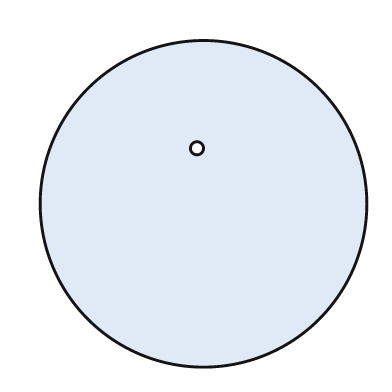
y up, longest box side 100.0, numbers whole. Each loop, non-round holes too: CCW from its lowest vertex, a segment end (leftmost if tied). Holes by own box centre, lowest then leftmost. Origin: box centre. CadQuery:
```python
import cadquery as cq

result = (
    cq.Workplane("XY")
    .moveTo(0.0, 0.0)
    .circle(50.0)
    .moveTo(-2.0, 17.0)
    .circle(2.0)
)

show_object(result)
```